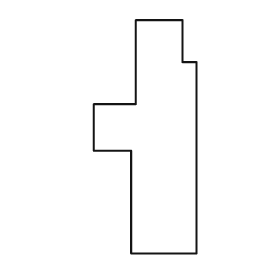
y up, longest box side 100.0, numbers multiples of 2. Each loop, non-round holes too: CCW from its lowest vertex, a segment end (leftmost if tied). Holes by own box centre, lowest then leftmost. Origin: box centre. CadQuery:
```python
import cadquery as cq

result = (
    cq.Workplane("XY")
    .moveTo(-6.0, -50.0)
    .lineTo(22.0, -50.0)
    .lineTo(22.0, 32.0)
    .lineTo(16.0, 32.0)
    .lineTo(16.0, 50.0)
    .lineTo(-4.0, 50.0)
    .lineTo(-4.0, 14.0)
    .lineTo(-22.0, 14.0)
    .lineTo(-22.0, -6.0)
    .lineTo(-6.0, -6.0)
    .close()
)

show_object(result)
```